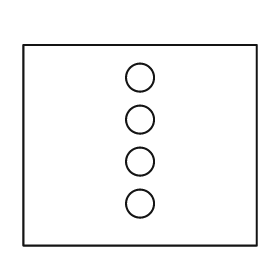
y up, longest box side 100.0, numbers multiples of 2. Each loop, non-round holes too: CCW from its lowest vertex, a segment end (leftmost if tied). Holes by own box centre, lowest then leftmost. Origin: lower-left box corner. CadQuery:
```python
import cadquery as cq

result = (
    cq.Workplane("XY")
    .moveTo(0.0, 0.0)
    .lineTo(100.0, 0.0)
    .lineTo(100.0, 86.0)
    .lineTo(0.0, 86.0)
    .close()
    .moveTo(50.0, 18.0)
    .circle(6.0)
    .moveTo(50.0, 36.0)
    .circle(6.0)
    .moveTo(50.0, 54.0)
    .circle(6.0)
    .moveTo(50.0, 72.0)
    .circle(6.0)
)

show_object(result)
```